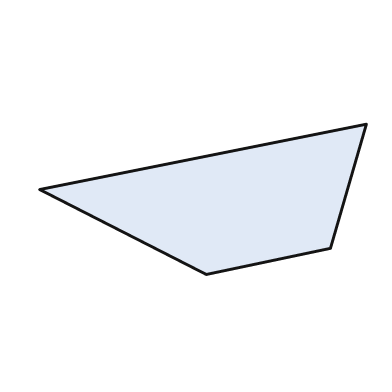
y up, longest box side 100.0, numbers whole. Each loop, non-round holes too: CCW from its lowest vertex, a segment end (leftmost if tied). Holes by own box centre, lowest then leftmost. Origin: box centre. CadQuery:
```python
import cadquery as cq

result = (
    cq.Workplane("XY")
    .moveTo(1.0, -23.0)
    .lineTo(39.0, -15.0)
    .lineTo(50.0, 23.0)
    .lineTo(-50.0, 3.0)
    .close()
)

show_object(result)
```